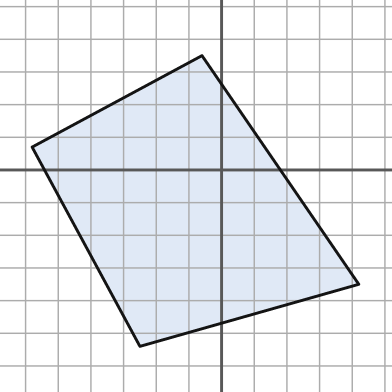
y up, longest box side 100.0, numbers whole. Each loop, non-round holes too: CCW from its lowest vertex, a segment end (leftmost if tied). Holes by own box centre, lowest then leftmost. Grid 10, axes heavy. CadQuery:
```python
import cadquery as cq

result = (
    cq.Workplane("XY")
    .moveTo(-25.0, -54.0)
    .lineTo(42.0, -35.0)
    .lineTo(-6.0, 35.0)
    .lineTo(-58.0, 7.0)
    .close()
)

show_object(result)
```